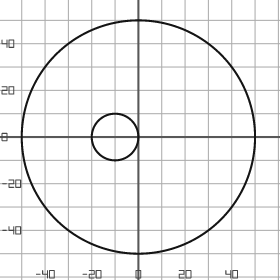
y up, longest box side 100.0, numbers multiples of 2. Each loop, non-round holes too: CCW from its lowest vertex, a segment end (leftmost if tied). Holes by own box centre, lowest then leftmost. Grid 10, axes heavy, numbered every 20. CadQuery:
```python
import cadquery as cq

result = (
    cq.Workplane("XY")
    .moveTo(0.0, 0.0)
    .circle(50.0)
    .moveTo(-10.0, 0.0)
    .circle(10.0)
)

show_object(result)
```